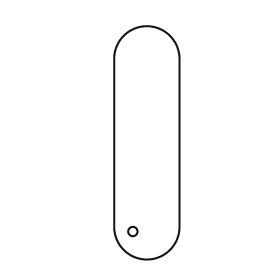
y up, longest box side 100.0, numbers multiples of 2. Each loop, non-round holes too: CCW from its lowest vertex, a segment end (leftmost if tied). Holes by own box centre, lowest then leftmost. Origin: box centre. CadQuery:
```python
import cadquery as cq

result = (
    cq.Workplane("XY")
    .moveTo(-14.0, -36.0)
    .threePointArc((0.0, -50.0), (14.0, -36.0))
    .lineTo(14.0, 36.0)
    .threePointArc((0.0, 50.0), (-14.0, 36.0))
    .close()
    .moveTo(-6.0, -38.0)
    .circle(2.0)
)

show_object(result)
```